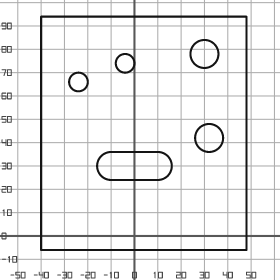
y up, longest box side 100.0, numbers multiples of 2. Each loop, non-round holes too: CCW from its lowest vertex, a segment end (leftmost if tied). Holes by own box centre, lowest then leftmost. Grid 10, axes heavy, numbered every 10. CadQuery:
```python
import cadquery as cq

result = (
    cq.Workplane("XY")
    .moveTo(-40.0, -6.0)
    .lineTo(48.0, -6.0)
    .lineTo(48.0, 94.0)
    .lineTo(-40.0, 94.0)
    .close()
    .moveTo(-10.0, 24.0)
    .lineTo(10.0, 24.0)
    .threePointArc((16.0, 30.0), (10.0, 36.0))
    .lineTo(-10.0, 36.0)
    .threePointArc((-16.0, 30.0), (-10.0, 24.0))
    .close()
    .moveTo(32.0, 42.0)
    .circle(6.0)
    .moveTo(-24.0, 66.0)
    .circle(4.0)
    .moveTo(-4.0, 74.0)
    .circle(4.0)
    .moveTo(30.0, 78.0)
    .circle(6.0)
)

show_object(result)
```